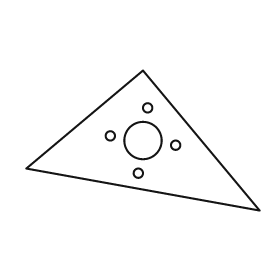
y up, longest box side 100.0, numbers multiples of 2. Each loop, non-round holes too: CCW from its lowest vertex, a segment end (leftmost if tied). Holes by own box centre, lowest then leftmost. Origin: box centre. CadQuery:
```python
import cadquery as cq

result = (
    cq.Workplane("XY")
    .moveTo(50.0, -30.0)
    .lineTo(0.0, 30.0)
    .lineTo(-50.0, -12.0)
    .close()
    .moveTo(-2.0, -14.0)
    .circle(2.0)
    .moveTo(14.0, -2.0)
    .circle(2.0)
    .moveTo(0.0, 0.0)
    .circle(8.0)
    .moveTo(-14.0, 2.0)
    .circle(2.0)
    .moveTo(2.0, 14.0)
    .circle(2.0)
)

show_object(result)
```